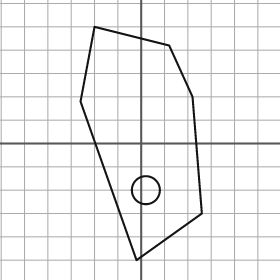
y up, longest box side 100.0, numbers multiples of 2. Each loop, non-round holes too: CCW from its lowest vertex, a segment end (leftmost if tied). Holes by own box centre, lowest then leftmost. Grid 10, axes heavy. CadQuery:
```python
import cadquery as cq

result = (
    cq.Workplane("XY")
    .moveTo(-2.0, -50.0)
    .lineTo(26.0, -30.0)
    .lineTo(22.0, 20.0)
    .lineTo(12.0, 42.0)
    .lineTo(-20.0, 50.0)
    .lineTo(-26.0, 18.0)
    .close()
    .moveTo(2.0, -20.0)
    .circle(6.0)
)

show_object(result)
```